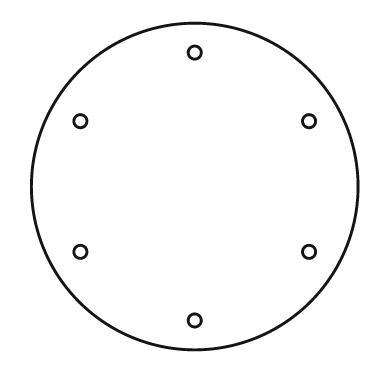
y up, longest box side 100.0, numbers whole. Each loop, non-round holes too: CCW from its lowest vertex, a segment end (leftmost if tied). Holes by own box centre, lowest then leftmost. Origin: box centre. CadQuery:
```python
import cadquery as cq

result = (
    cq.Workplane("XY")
    .moveTo(0.0, 0.0)
    .circle(50.0)
    .moveTo(0.0, -41.0)
    .circle(2.0)
    .moveTo(-35.0, -20.0)
    .circle(2.0)
    .moveTo(35.0, -20.0)
    .circle(2.0)
    .moveTo(-35.0, 20.0)
    .circle(2.0)
    .moveTo(35.0, 20.0)
    .circle(2.0)
    .moveTo(0.0, 41.0)
    .circle(2.0)
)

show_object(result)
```